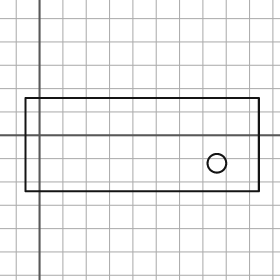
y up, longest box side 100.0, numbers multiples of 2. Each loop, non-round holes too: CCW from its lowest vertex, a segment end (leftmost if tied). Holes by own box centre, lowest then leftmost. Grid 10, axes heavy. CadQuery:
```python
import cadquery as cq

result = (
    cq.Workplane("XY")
    .moveTo(-6.0, -24.0)
    .lineTo(94.0, -24.0)
    .lineTo(94.0, 16.0)
    .lineTo(-6.0, 16.0)
    .close()
    .moveTo(76.0, -12.0)
    .circle(4.0)
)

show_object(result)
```